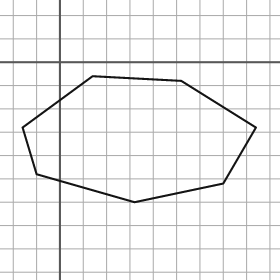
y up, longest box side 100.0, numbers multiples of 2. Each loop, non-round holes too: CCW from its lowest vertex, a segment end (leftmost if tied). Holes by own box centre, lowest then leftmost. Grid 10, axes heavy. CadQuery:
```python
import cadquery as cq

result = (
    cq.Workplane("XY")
    .moveTo(32.0, -60.0)
    .lineTo(70.0, -52.0)
    .lineTo(84.0, -28.0)
    .lineTo(52.0, -8.0)
    .lineTo(14.0, -6.0)
    .lineTo(-16.0, -28.0)
    .lineTo(-10.0, -48.0)
    .close()
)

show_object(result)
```